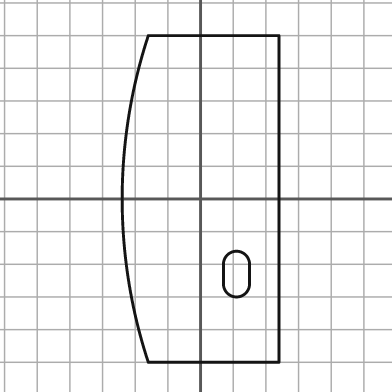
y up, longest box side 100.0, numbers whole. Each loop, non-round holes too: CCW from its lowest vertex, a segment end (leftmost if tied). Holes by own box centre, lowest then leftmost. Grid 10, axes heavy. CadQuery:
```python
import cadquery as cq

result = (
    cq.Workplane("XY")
    .moveTo(-16.0, -50.0)
    .lineTo(24.0, -50.0)
    .lineTo(24.0, 50.0)
    .lineTo(-16.0, 50.0)
    .threePointArc((-24.0, 0.0), (-16.0, -50.0))
    .close()
    .moveTo(7.0, -26.0)
    .threePointArc((11.0, -30.0), (15.0, -26.0))
    .lineTo(15.0, -20.0)
    .threePointArc((11.0, -16.0), (7.0, -20.0))
    .close()
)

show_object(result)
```